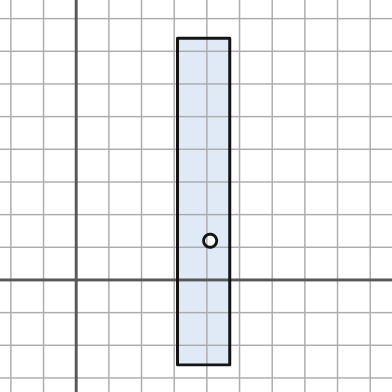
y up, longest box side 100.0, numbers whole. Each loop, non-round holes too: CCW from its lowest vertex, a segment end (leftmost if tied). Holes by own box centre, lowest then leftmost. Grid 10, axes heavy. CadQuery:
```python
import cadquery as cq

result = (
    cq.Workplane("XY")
    .moveTo(31.0, -26.0)
    .lineTo(47.0, -26.0)
    .lineTo(47.0, 74.0)
    .lineTo(31.0, 74.0)
    .close()
    .moveTo(41.0, 12.0)
    .circle(2.0)
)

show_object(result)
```